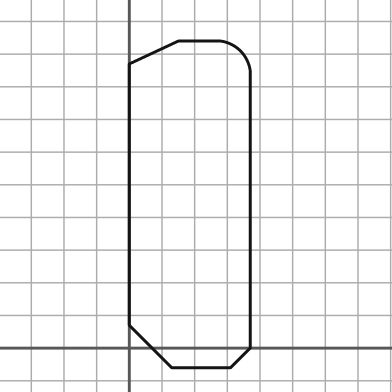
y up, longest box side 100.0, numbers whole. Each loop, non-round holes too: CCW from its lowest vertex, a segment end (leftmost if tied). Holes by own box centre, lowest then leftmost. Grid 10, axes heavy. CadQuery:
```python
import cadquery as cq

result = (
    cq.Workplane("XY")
    .moveTo(13.0, -6.0)
    .lineTo(31.0, -6.0)
    .lineTo(37.0, 0.0)
    .lineTo(37.0, 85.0)
    .threePointArc((34.0, 91.0), (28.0, 94.0))
    .lineTo(15.0, 94.0)
    .lineTo(0.0, 87.0)
    .lineTo(0.0, 7.0)
    .close()
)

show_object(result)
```